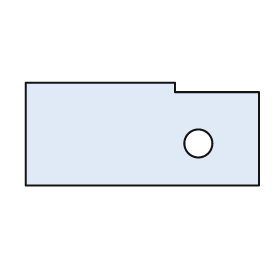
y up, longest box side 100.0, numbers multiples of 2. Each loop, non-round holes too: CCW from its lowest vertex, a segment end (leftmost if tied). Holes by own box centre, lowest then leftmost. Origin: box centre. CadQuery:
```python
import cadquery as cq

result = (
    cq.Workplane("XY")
    .moveTo(-50.0, -22.0)
    .lineTo(50.0, -22.0)
    .lineTo(50.0, 18.0)
    .lineTo(14.0, 18.0)
    .lineTo(14.0, 22.0)
    .lineTo(-50.0, 22.0)
    .close()
    .moveTo(24.0, -4.0)
    .circle(6.0)
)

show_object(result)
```